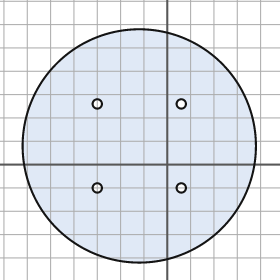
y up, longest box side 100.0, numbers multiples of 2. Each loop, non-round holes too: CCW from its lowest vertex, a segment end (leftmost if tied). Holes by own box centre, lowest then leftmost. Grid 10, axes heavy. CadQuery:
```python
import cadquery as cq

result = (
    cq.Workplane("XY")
    .moveTo(-12.0, 8.0)
    .circle(50.0)
    .moveTo(-30.0, -10.0)
    .circle(2.0)
    .moveTo(6.0, -10.0)
    .circle(2.0)
    .moveTo(-30.0, 26.0)
    .circle(2.0)
    .moveTo(6.0, 26.0)
    .circle(2.0)
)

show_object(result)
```